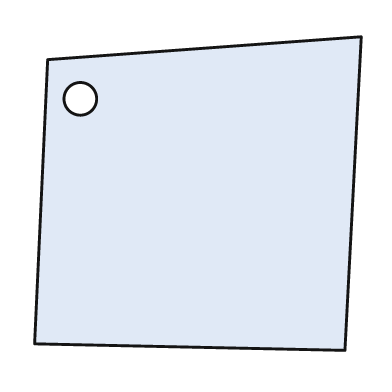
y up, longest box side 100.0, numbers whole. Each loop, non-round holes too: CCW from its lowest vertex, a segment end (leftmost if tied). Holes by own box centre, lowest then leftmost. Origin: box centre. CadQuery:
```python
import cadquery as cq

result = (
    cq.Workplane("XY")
    .moveTo(45.0, -48.0)
    .lineTo(50.0, 48.0)
    .lineTo(-46.0, 41.0)
    .lineTo(-50.0, -46.0)
    .close()
    .moveTo(-36.0, 29.0)
    .circle(5.0)
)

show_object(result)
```